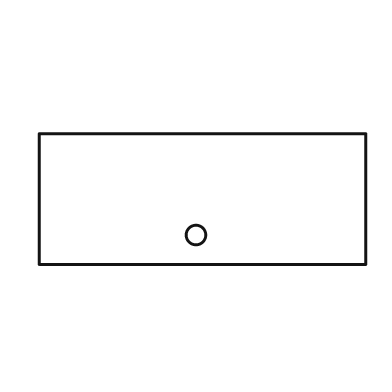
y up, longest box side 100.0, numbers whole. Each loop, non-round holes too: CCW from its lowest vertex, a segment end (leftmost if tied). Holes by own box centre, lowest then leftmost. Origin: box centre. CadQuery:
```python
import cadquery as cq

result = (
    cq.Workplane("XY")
    .moveTo(-50.0, -20.0)
    .lineTo(50.0, -20.0)
    .lineTo(50.0, 20.0)
    .lineTo(-50.0, 20.0)
    .close()
    .moveTo(-2.0, -11.0)
    .circle(3.0)
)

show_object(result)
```